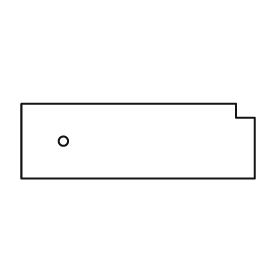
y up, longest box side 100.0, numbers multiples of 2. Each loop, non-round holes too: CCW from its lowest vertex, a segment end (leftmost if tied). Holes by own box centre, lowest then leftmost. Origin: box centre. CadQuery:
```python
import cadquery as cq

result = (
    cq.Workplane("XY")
    .moveTo(-50.0, -16.0)
    .lineTo(50.0, -16.0)
    .lineTo(50.0, 10.0)
    .lineTo(42.0, 10.0)
    .lineTo(42.0, 16.0)
    .lineTo(-50.0, 16.0)
    .close()
    .moveTo(-32.0, 0.0)
    .circle(2.0)
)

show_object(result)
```